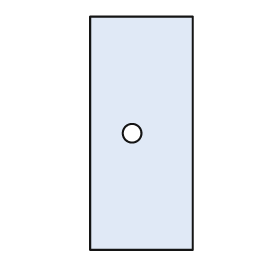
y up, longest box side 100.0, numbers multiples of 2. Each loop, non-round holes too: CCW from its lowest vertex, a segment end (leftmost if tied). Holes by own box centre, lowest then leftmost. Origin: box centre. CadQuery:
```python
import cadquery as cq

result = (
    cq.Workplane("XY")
    .moveTo(-22.0, -50.0)
    .lineTo(22.0, -50.0)
    .lineTo(22.0, 50.0)
    .lineTo(-22.0, 50.0)
    .close()
    .moveTo(-4.0, 0.0)
    .circle(4.0)
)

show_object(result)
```